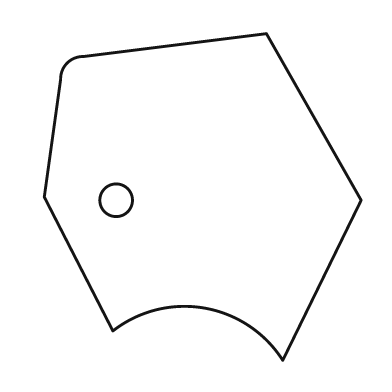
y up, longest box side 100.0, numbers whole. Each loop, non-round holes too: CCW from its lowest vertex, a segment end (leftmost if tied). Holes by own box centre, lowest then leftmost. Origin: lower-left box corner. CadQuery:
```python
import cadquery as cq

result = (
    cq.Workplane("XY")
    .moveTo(73.0, 0.0)
    .lineTo(97.0, 49.0)
    .lineTo(68.0, 100.0)
    .lineTo(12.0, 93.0)
    .threePointArc((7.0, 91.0), (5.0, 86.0))
    .lineTo(0.0, 50.0)
    .lineTo(21.0, 9.0)
    .threePointArc((49.0, 16.0), (73.0, 0.0))
    .close()
    .moveTo(22.0, 49.0)
    .circle(5.0)
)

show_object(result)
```